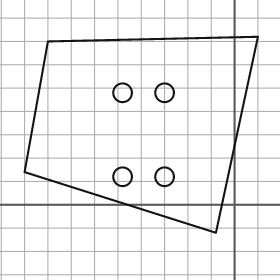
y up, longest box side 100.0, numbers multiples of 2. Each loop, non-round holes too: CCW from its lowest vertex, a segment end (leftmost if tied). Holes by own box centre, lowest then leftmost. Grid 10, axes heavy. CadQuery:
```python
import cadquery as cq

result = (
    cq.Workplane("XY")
    .moveTo(-8.0, -12.0)
    .lineTo(10.0, 72.0)
    .lineTo(-80.0, 70.0)
    .lineTo(-90.0, 14.0)
    .close()
    .moveTo(-48.0, 12.0)
    .circle(4.0)
    .moveTo(-30.0, 12.0)
    .circle(4.0)
    .moveTo(-48.0, 48.0)
    .circle(4.0)
    .moveTo(-30.0, 48.0)
    .circle(4.0)
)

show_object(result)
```